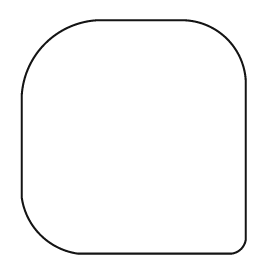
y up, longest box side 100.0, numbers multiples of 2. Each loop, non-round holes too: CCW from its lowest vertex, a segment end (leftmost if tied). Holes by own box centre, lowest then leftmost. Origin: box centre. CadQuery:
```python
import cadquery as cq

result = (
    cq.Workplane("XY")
    .moveTo(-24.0, -50.0)
    .lineTo(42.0, -50.0)
    .threePointArc((46.0, -48.0), (48.0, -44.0))
    .lineTo(48.0, 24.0)
    .threePointArc((40.0, 42.0), (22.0, 50.0))
    .lineTo(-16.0, 50.0)
    .threePointArc((-38.0, 40.0), (-48.0, 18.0))
    .lineTo(-48.0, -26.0)
    .threePointArc((-40.0, -42.0), (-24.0, -50.0))
    .close()
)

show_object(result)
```